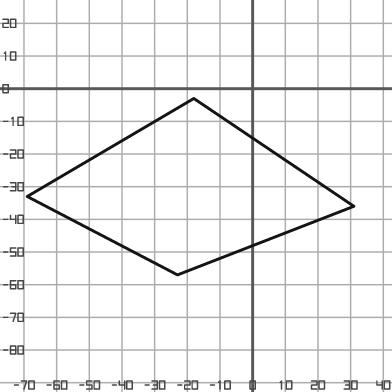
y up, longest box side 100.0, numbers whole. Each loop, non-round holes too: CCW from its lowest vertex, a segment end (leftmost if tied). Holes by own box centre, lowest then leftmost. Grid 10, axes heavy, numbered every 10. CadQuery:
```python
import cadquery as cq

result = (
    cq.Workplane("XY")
    .moveTo(-23.0, -57.0)
    .lineTo(31.0, -36.0)
    .lineTo(-18.0, -3.0)
    .lineTo(-69.0, -33.0)
    .close()
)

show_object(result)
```